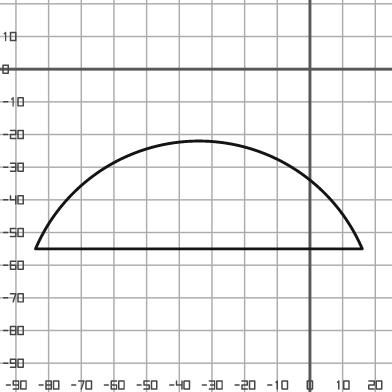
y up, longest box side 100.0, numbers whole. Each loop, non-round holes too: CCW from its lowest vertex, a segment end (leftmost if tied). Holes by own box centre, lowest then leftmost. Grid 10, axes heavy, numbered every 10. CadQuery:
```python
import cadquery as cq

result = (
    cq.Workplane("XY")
    .moveTo(-84.0, -55.0)
    .lineTo(16.0, -55.0)
    .threePointArc((-34.0, -22.0), (-84.0, -55.0))
    .close()
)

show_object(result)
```